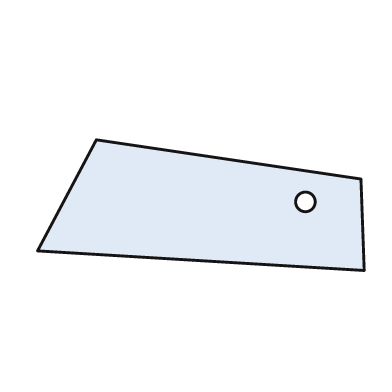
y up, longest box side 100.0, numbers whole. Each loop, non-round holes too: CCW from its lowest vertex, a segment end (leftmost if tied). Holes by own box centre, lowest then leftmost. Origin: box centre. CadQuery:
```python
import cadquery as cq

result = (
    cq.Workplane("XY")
    .moveTo(50.0, -20.0)
    .lineTo(49.0, 8.0)
    .lineTo(-32.0, 20.0)
    .lineTo(-50.0, -14.0)
    .close()
    .moveTo(32.0, 1.0)
    .circle(3.0)
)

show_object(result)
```